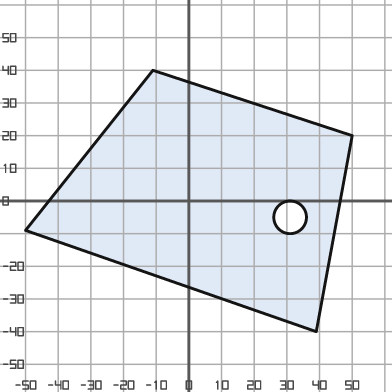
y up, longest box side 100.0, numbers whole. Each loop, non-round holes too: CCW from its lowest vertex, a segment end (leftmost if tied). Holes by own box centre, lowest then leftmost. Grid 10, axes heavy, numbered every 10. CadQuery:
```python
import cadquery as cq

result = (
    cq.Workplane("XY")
    .moveTo(39.0, -40.0)
    .lineTo(50.0, 20.0)
    .lineTo(-11.0, 40.0)
    .lineTo(-50.0, -9.0)
    .close()
    .moveTo(31.0, -5.0)
    .circle(5.0)
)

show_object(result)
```